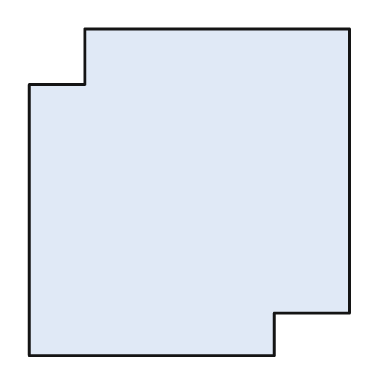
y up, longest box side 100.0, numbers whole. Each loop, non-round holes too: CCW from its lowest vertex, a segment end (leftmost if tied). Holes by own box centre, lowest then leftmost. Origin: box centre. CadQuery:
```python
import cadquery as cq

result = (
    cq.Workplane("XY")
    .moveTo(-49.0, -50.0)
    .lineTo(26.0, -50.0)
    .lineTo(26.0, -37.0)
    .lineTo(49.0, -37.0)
    .lineTo(49.0, 50.0)
    .lineTo(-32.0, 50.0)
    .lineTo(-32.0, 33.0)
    .lineTo(-49.0, 33.0)
    .close()
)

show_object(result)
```